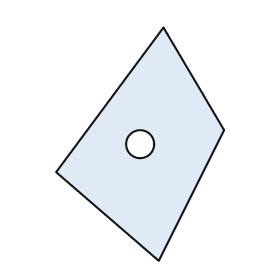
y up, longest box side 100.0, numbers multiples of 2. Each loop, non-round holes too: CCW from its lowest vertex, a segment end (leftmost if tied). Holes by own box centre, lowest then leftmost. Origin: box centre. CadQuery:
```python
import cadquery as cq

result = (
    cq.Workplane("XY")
    .moveTo(8.0, -50.0)
    .lineTo(36.0, 6.0)
    .lineTo(10.0, 50.0)
    .lineTo(-36.0, -12.0)
    .close()
    .moveTo(0.0, 0.0)
    .circle(6.0)
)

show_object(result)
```